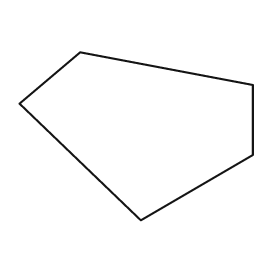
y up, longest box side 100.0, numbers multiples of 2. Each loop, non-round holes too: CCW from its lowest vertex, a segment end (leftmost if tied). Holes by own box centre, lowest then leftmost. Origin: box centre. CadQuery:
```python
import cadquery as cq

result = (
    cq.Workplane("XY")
    .moveTo(2.0, -36.0)
    .lineTo(50.0, -8.0)
    .lineTo(50.0, 22.0)
    .lineTo(-24.0, 36.0)
    .lineTo(-50.0, 14.0)
    .close()
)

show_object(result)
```